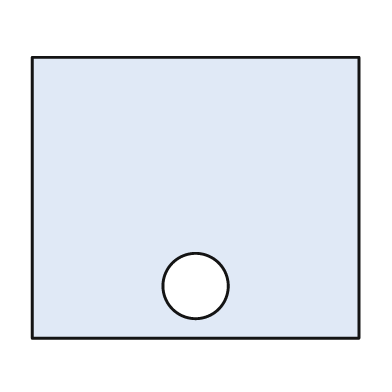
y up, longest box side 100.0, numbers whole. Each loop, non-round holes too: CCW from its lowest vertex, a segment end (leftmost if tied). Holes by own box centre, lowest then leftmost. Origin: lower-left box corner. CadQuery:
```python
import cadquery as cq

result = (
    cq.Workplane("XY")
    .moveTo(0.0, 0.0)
    .lineTo(100.0, 0.0)
    .lineTo(100.0, 86.0)
    .lineTo(0.0, 86.0)
    .close()
    .moveTo(50.0, 16.0)
    .circle(10.0)
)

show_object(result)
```